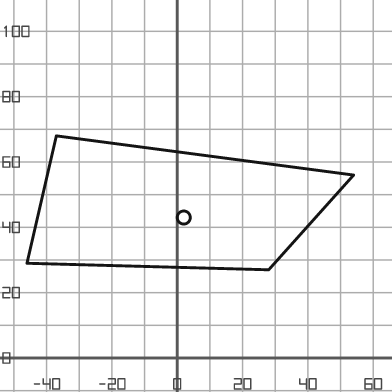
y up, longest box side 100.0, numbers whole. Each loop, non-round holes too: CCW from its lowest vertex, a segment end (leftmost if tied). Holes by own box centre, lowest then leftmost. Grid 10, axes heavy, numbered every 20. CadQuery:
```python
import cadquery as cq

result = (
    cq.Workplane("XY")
    .moveTo(28.0, 27.0)
    .lineTo(54.0, 56.0)
    .lineTo(-37.0, 68.0)
    .lineTo(-46.0, 29.0)
    .close()
    .moveTo(2.0, 43.0)
    .circle(2.0)
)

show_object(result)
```